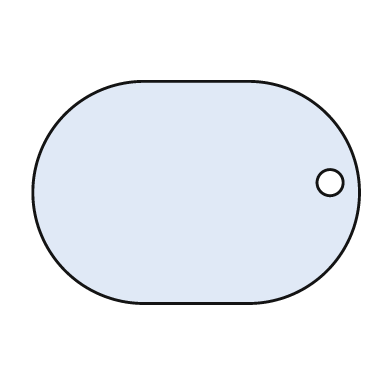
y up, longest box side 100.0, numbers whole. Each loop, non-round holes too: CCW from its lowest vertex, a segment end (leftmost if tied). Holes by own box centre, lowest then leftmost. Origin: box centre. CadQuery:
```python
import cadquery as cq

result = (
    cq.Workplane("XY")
    .moveTo(-16.0, -34.0)
    .lineTo(16.0, -34.0)
    .threePointArc((50.0, 0.0), (16.0, 34.0))
    .lineTo(-16.0, 34.0)
    .threePointArc((-50.0, 0.0), (-16.0, -34.0))
    .close()
    .moveTo(41.0, 3.0)
    .circle(4.0)
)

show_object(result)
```